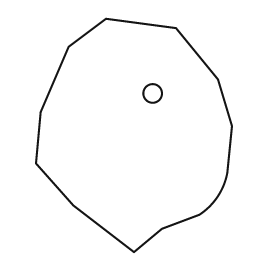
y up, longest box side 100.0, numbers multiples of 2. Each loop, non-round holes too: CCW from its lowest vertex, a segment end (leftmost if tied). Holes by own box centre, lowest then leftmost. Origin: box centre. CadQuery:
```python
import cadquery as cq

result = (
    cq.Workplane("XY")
    .moveTo(0.0, -50.0)
    .lineTo(12.0, -40.0)
    .lineTo(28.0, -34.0)
    .threePointArc((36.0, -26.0), (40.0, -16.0))
    .lineTo(42.0, 4.0)
    .lineTo(36.0, 24.0)
    .lineTo(18.0, 46.0)
    .lineTo(-12.0, 50.0)
    .lineTo(-28.0, 38.0)
    .lineTo(-40.0, 10.0)
    .lineTo(-42.0, -12.0)
    .lineTo(-26.0, -30.0)
    .close()
    .moveTo(8.0, 18.0)
    .circle(4.0)
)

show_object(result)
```